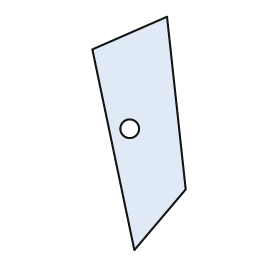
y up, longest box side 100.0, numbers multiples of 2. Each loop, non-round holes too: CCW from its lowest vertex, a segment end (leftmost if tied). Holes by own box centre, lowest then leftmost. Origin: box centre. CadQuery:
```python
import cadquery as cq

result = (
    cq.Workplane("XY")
    .moveTo(-2.0, -50.0)
    .lineTo(20.0, -24.0)
    .lineTo(12.0, 50.0)
    .lineTo(-20.0, 36.0)
    .close()
    .moveTo(-4.0, 2.0)
    .circle(4.0)
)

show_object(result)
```